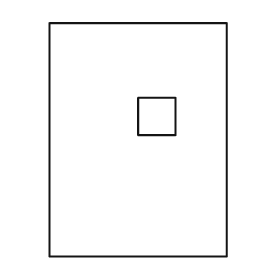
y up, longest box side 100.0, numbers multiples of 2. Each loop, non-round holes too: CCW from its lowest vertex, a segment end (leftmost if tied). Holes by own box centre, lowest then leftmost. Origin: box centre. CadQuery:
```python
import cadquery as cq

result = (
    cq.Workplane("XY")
    .moveTo(-38.0, -50.0)
    .lineTo(38.0, -50.0)
    .lineTo(38.0, 50.0)
    .lineTo(-38.0, 50.0)
    .close()
    .moveTo(0.0, 2.0)
    .lineTo(16.0, 2.0)
    .lineTo(16.0, 18.0)
    .lineTo(0.0, 18.0)
    .close()
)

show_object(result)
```